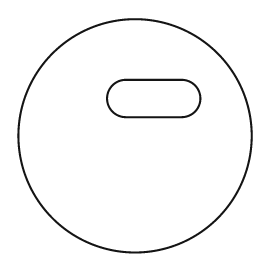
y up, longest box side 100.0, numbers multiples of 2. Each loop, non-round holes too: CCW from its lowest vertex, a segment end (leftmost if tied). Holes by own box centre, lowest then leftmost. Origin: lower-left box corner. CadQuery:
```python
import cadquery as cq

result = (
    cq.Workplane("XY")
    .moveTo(50.0, 50.0)
    .circle(50.0)
    .moveTo(46.0, 58.0)
    .lineTo(70.0, 58.0)
    .threePointArc((78.0, 66.0), (70.0, 74.0))
    .lineTo(46.0, 74.0)
    .threePointArc((38.0, 66.0), (46.0, 58.0))
    .close()
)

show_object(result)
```